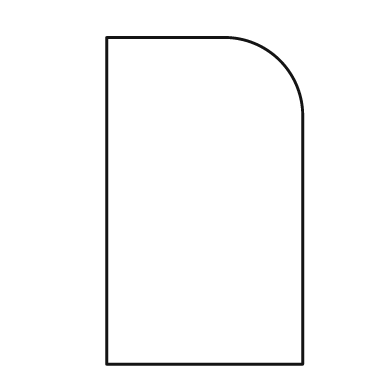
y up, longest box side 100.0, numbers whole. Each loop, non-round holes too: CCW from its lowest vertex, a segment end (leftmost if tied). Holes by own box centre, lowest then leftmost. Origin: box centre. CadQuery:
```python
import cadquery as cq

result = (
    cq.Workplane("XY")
    .moveTo(-30.0, -50.0)
    .lineTo(30.0, -50.0)
    .lineTo(30.0, 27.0)
    .threePointArc((23.0, 43.0), (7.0, 50.0))
    .lineTo(-30.0, 50.0)
    .close()
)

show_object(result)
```